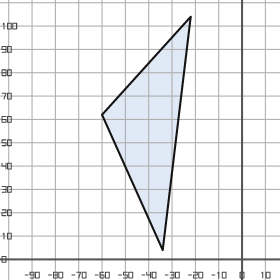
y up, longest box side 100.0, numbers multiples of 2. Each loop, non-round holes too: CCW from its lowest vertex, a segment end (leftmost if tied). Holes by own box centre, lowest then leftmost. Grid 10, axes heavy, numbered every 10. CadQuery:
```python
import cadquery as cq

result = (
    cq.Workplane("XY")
    .moveTo(-34.0, 4.0)
    .lineTo(-22.0, 104.0)
    .lineTo(-60.0, 62.0)
    .close()
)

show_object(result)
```